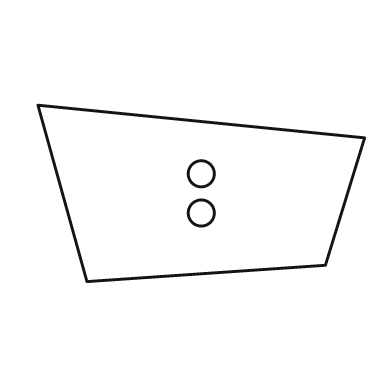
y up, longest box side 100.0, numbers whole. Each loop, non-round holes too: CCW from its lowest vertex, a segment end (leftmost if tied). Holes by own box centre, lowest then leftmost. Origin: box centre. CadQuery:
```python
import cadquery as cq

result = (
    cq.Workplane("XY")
    .moveTo(-35.0, -27.0)
    .lineTo(38.0, -22.0)
    .lineTo(50.0, 17.0)
    .lineTo(-50.0, 27.0)
    .close()
    .moveTo(0.0, -6.0)
    .circle(4.0)
    .moveTo(0.0, 6.0)
    .circle(4.0)
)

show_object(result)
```